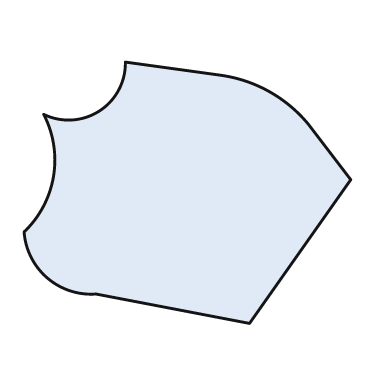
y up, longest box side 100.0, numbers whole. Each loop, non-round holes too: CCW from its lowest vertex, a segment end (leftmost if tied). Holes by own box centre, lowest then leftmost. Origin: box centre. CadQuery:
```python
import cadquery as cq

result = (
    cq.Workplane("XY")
    .moveTo(19.0, -40.0)
    .lineTo(50.0, 4.0)
    .lineTo(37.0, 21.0)
    .threePointArc((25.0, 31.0), (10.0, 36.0))
    .lineTo(-19.0, 40.0)
    .threePointArc((-27.0, 25.0), (-44.0, 24.0))
    .threePointArc((-41.0, 5.0), (-50.0, -12.0))
    .threePointArc((-43.0, -26.0), (-28.0, -31.0))
    .close()
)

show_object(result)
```